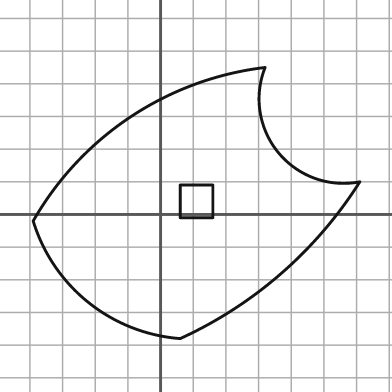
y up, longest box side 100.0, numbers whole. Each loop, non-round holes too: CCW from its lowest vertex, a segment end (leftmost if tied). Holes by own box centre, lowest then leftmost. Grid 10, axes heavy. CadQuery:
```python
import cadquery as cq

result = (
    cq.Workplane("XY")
    .moveTo(6.0, -38.0)
    .threePointArc((37.0, -18.0), (61.0, 10.0))
    .threePointArc((36.0, 19.0), (32.0, 45.0))
    .threePointArc((-9.0, 30.0), (-39.0, -2.0))
    .threePointArc((-22.0, -27.0), (6.0, -38.0))
    .close()
    .moveTo(6.0, -1.0)
    .lineTo(16.0, -1.0)
    .lineTo(16.0, 9.0)
    .lineTo(6.0, 9.0)
    .close()
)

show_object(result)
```